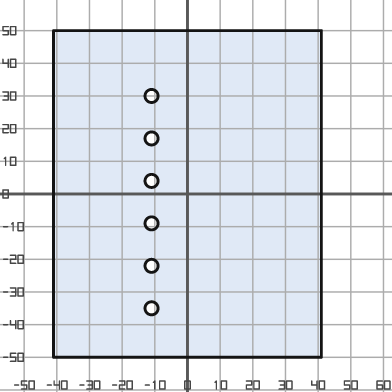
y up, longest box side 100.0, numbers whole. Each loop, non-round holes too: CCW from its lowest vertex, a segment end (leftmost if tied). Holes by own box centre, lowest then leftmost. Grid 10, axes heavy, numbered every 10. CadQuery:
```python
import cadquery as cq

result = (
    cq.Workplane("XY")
    .moveTo(-41.0, -50.0)
    .lineTo(41.0, -50.0)
    .lineTo(41.0, 50.0)
    .lineTo(-41.0, 50.0)
    .close()
    .moveTo(-11.0, -35.0)
    .circle(2.0)
    .moveTo(-11.0, -22.0)
    .circle(2.0)
    .moveTo(-11.0, -9.0)
    .circle(2.0)
    .moveTo(-11.0, 4.0)
    .circle(2.0)
    .moveTo(-11.0, 17.0)
    .circle(2.0)
    .moveTo(-11.0, 30.0)
    .circle(2.0)
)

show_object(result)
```